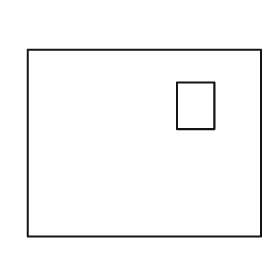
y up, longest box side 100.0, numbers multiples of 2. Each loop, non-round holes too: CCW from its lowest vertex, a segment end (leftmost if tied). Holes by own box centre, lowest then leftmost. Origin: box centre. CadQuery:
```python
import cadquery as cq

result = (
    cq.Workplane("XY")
    .moveTo(-50.0, -40.0)
    .lineTo(50.0, -40.0)
    .lineTo(50.0, 40.0)
    .lineTo(-50.0, 40.0)
    .close()
    .moveTo(14.0, 6.0)
    .lineTo(30.0, 6.0)
    .lineTo(30.0, 26.0)
    .lineTo(14.0, 26.0)
    .close()
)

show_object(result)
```